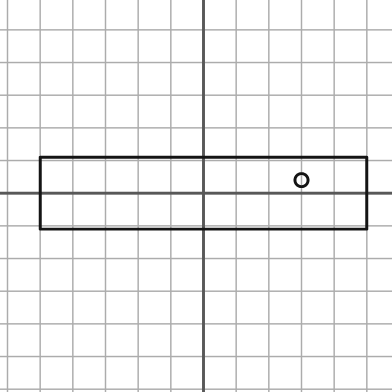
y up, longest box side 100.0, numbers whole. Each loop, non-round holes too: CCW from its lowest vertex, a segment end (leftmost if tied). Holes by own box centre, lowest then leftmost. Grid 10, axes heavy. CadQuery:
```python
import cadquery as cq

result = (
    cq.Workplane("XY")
    .moveTo(-50.0, -11.0)
    .lineTo(50.0, -11.0)
    .lineTo(50.0, 11.0)
    .lineTo(-50.0, 11.0)
    .close()
    .moveTo(30.0, 4.0)
    .circle(2.0)
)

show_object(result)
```